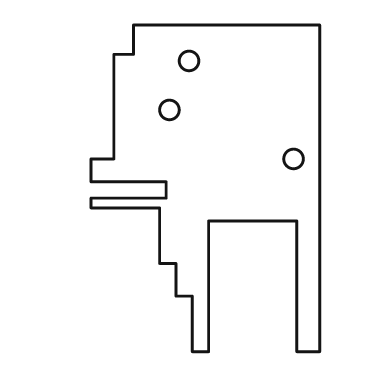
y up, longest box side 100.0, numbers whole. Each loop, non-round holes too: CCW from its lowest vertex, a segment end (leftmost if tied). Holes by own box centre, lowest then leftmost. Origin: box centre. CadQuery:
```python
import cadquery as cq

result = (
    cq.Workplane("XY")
    .moveTo(-4.0, -50.0)
    .lineTo(1.0, -50.0)
    .lineTo(1.0, -10.0)
    .lineTo(28.0, -10.0)
    .lineTo(28.0, -50.0)
    .lineTo(35.0, -50.0)
    .lineTo(35.0, 50.0)
    .lineTo(-22.0, 50.0)
    .lineTo(-22.0, 41.0)
    .lineTo(-28.0, 41.0)
    .lineTo(-28.0, 9.0)
    .lineTo(-35.0, 9.0)
    .lineTo(-35.0, 2.0)
    .lineTo(-12.0, 2.0)
    .lineTo(-12.0, -3.0)
    .lineTo(-35.0, -3.0)
    .lineTo(-35.0, -6.0)
    .lineTo(-14.0, -6.0)
    .lineTo(-14.0, -23.0)
    .lineTo(-9.0, -23.0)
    .lineTo(-9.0, -33.0)
    .lineTo(-4.0, -33.0)
    .close()
    .moveTo(27.0, 9.0)
    .circle(3.0)
    .moveTo(-11.0, 24.0)
    .circle(3.0)
    .moveTo(-5.0, 39.0)
    .circle(3.0)
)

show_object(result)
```